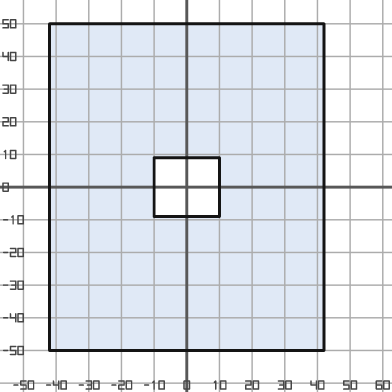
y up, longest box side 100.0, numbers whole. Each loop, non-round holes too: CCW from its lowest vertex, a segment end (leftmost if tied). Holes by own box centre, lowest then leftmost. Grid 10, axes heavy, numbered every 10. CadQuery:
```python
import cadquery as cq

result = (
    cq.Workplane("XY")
    .moveTo(-42.0, -50.0)
    .lineTo(42.0, -50.0)
    .lineTo(42.0, 50.0)
    .lineTo(-42.0, 50.0)
    .close()
    .moveTo(-10.0, -9.0)
    .lineTo(10.0, -9.0)
    .lineTo(10.0, 9.0)
    .lineTo(-10.0, 9.0)
    .close()
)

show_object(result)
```